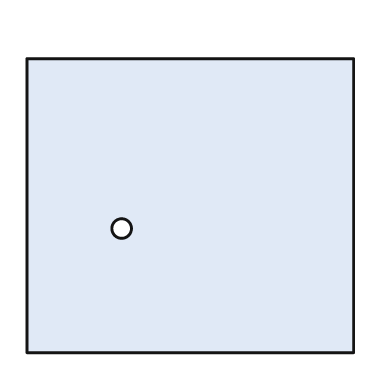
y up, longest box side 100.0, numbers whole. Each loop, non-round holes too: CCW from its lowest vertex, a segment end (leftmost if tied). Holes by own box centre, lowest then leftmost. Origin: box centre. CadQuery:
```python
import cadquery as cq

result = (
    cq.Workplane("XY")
    .moveTo(-50.0, -45.0)
    .lineTo(50.0, -45.0)
    .lineTo(50.0, 45.0)
    .lineTo(-50.0, 45.0)
    .close()
    .moveTo(-21.0, -7.0)
    .circle(3.0)
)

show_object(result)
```